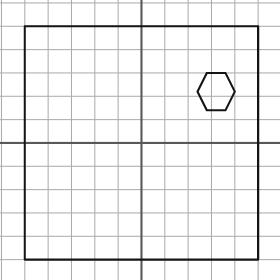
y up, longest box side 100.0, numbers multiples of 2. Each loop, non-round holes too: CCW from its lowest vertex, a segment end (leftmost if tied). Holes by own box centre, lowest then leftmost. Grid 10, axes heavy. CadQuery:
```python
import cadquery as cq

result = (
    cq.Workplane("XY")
    .moveTo(-50.0, -50.0)
    .lineTo(50.0, -50.0)
    .lineTo(50.0, 50.0)
    .lineTo(-50.0, 50.0)
    .close()
    .moveTo(28.0, 14.0)
    .lineTo(36.0, 14.0)
    .lineTo(40.0, 22.0)
    .lineTo(36.0, 30.0)
    .lineTo(28.0, 30.0)
    .lineTo(24.0, 22.0)
    .close()
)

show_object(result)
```